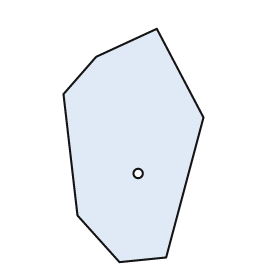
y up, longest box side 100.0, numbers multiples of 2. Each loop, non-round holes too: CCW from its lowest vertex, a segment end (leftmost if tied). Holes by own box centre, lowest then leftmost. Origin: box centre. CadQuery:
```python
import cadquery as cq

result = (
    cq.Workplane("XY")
    .moveTo(-6.0, -50.0)
    .lineTo(14.0, -48.0)
    .lineTo(30.0, 12.0)
    .lineTo(10.0, 50.0)
    .lineTo(-16.0, 38.0)
    .lineTo(-30.0, 22.0)
    .lineTo(-24.0, -30.0)
    .close()
    .moveTo(2.0, -12.0)
    .circle(2.0)
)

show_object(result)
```